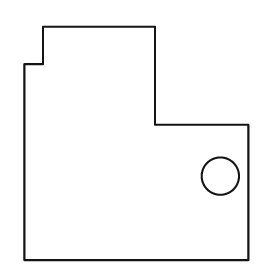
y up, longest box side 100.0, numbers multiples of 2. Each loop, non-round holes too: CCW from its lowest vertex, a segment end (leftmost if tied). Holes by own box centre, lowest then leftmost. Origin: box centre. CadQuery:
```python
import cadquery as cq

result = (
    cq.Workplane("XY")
    .moveTo(-48.0, -50.0)
    .lineTo(48.0, -50.0)
    .lineTo(48.0, 8.0)
    .lineTo(8.0, 8.0)
    .lineTo(8.0, 50.0)
    .lineTo(-40.0, 50.0)
    .lineTo(-40.0, 34.0)
    .lineTo(-48.0, 34.0)
    .close()
    .moveTo(36.0, -14.0)
    .circle(8.0)
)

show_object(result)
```